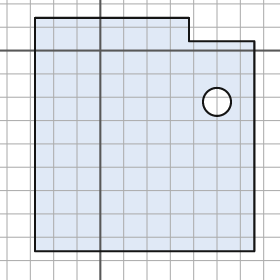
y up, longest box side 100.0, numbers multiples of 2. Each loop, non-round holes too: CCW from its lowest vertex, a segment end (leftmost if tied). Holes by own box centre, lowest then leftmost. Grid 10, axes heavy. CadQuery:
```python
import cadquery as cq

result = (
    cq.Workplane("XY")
    .moveTo(-28.0, -86.0)
    .lineTo(66.0, -86.0)
    .lineTo(66.0, 4.0)
    .lineTo(38.0, 4.0)
    .lineTo(38.0, 14.0)
    .lineTo(-28.0, 14.0)
    .close()
    .moveTo(50.0, -22.0)
    .circle(6.0)
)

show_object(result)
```